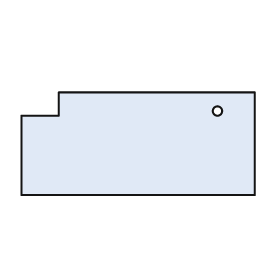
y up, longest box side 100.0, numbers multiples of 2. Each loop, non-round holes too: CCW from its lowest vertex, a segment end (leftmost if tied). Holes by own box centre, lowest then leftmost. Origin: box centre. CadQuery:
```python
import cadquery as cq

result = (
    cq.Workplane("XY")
    .moveTo(-50.0, -22.0)
    .lineTo(50.0, -22.0)
    .lineTo(50.0, 22.0)
    .lineTo(-34.0, 22.0)
    .lineTo(-34.0, 12.0)
    .lineTo(-50.0, 12.0)
    .close()
    .moveTo(34.0, 14.0)
    .circle(2.0)
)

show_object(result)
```